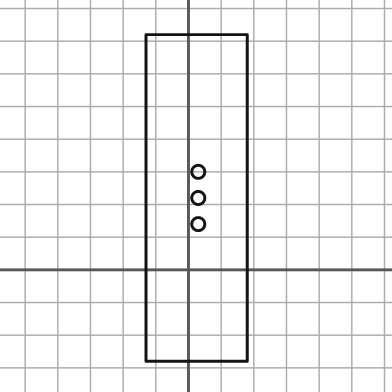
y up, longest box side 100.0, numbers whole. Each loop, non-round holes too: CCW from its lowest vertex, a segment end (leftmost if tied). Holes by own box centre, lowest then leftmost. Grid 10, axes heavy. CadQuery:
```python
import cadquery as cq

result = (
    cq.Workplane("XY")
    .moveTo(-13.0, -28.0)
    .lineTo(18.0, -28.0)
    .lineTo(18.0, 72.0)
    .lineTo(-13.0, 72.0)
    .close()
    .moveTo(3.0, 14.0)
    .circle(2.0)
    .moveTo(3.0, 22.0)
    .circle(2.0)
    .moveTo(3.0, 30.0)
    .circle(2.0)
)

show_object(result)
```